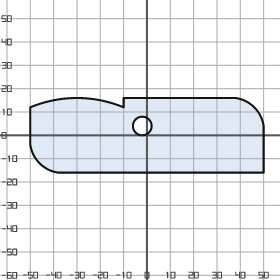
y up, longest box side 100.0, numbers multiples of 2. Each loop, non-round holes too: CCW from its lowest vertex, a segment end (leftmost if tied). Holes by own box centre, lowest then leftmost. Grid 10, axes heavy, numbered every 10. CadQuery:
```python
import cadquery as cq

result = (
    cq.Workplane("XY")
    .moveTo(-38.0, -16.0)
    .lineTo(50.0, -16.0)
    .lineTo(50.0, 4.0)
    .threePointArc((46.0, 12.0), (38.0, 16.0))
    .lineTo(-10.0, 16.0)
    .lineTo(-10.0, 12.0)
    .threePointArc((-30.0, 16.0), (-50.0, 12.0))
    .lineTo(-50.0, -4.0)
    .threePointArc((-46.0, -12.0), (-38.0, -16.0))
    .close()
    .moveTo(-2.0, 4.0)
    .circle(4.0)
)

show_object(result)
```